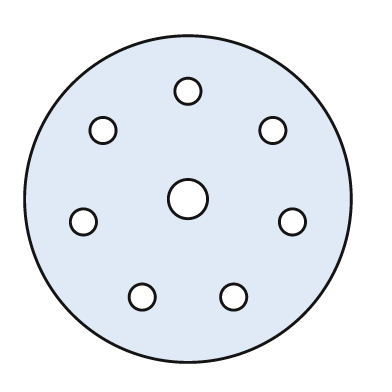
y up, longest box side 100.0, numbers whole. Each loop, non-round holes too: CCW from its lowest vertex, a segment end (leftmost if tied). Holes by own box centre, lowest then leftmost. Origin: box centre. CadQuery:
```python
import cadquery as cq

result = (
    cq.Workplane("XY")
    .moveTo(0.0, 0.0)
    .circle(50.0)
    .moveTo(-14.0, -30.0)
    .circle(4.0)
    .moveTo(14.0, -30.0)
    .circle(4.0)
    .moveTo(-32.0, -7.0)
    .circle(4.0)
    .moveTo(32.0, -7.0)
    .circle(4.0)
    .moveTo(0.0, 0.0)
    .circle(6.0)
    .moveTo(-26.0, 21.0)
    .circle(4.0)
    .moveTo(26.0, 21.0)
    .circle(4.0)
    .moveTo(0.0, 33.0)
    .circle(4.0)
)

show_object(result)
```